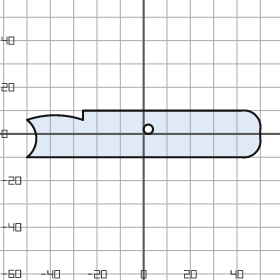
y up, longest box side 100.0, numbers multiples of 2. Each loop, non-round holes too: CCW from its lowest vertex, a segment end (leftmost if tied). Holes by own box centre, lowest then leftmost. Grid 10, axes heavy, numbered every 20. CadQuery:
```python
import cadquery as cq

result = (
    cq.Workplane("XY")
    .moveTo(-50.0, -10.0)
    .lineTo(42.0, -10.0)
    .threePointArc((48.0, -8.0), (50.0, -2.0))
    .lineTo(50.0, 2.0)
    .threePointArc((48.0, 8.0), (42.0, 10.0))
    .lineTo(-26.0, 10.0)
    .lineTo(-26.0, 6.0)
    .threePointArc((-38.0, 8.0), (-50.0, 6.0))
    .threePointArc((-46.0, -2.0), (-50.0, -10.0))
    .close()
    .moveTo(2.0, 2.0)
    .circle(2.0)
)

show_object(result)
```